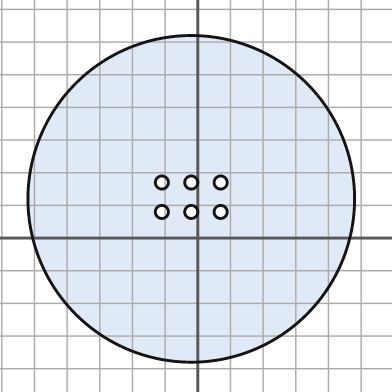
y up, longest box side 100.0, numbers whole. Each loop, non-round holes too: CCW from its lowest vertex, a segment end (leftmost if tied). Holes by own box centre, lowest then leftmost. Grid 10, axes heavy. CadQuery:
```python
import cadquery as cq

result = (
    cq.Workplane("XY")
    .moveTo(-2.0, 12.0)
    .circle(50.0)
    .moveTo(-11.0, 8.0)
    .circle(2.0)
    .moveTo(-2.0, 8.0)
    .circle(2.0)
    .moveTo(7.0, 8.0)
    .circle(2.0)
    .moveTo(-11.0, 17.0)
    .circle(2.0)
    .moveTo(-2.0, 17.0)
    .circle(2.0)
    .moveTo(7.0, 17.0)
    .circle(2.0)
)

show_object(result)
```